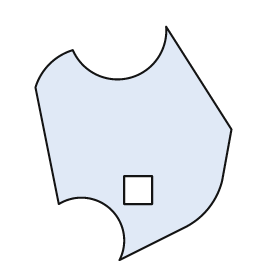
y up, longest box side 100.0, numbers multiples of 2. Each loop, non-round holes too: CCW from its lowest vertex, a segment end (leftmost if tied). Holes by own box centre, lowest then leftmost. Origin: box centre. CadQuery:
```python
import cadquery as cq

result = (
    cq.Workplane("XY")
    .moveTo(-6.0, -50.0)
    .lineTo(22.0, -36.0)
    .threePointArc((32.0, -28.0), (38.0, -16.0))
    .lineTo(42.0, 6.0)
    .lineTo(14.0, 50.0)
    .threePointArc((-2.0, 28.0), (-26.0, 40.0))
    .threePointArc((-36.0, 34.0), (-42.0, 24.0))
    .lineTo(-32.0, -26.0)
    .threePointArc((-10.0, -28.0), (-6.0, -50.0))
    .close()
    .moveTo(-4.0, -26.0)
    .lineTo(8.0, -26.0)
    .lineTo(8.0, -14.0)
    .lineTo(-4.0, -14.0)
    .close()
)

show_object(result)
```